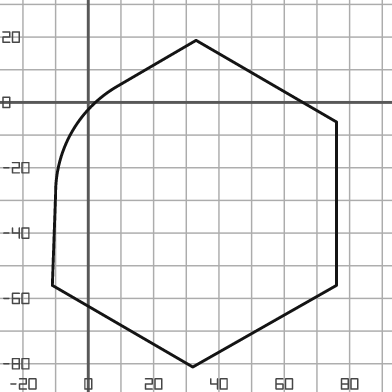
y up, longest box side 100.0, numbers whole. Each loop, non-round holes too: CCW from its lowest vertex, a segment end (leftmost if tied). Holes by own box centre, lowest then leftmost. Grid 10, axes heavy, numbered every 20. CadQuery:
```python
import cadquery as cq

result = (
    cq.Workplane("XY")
    .moveTo(32.0, -81.0)
    .lineTo(76.0, -56.0)
    .lineTo(76.0, -6.0)
    .lineTo(33.0, 19.0)
    .lineTo(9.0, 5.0)
    .threePointArc((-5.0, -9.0), (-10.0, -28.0))
    .lineTo(-11.0, -56.0)
    .close()
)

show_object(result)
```